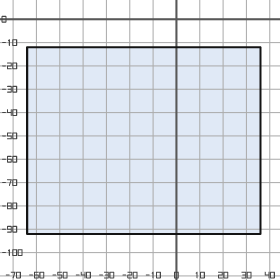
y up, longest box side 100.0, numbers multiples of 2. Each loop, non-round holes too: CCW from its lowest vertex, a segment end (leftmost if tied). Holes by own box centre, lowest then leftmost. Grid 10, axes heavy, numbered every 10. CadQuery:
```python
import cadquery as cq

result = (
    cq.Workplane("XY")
    .moveTo(-64.0, -92.0)
    .lineTo(36.0, -92.0)
    .lineTo(36.0, -12.0)
    .lineTo(-64.0, -12.0)
    .close()
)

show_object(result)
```